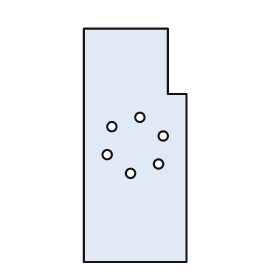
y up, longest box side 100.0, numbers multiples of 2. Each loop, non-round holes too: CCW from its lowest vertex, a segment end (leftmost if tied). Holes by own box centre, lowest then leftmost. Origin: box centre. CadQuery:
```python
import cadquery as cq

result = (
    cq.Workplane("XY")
    .moveTo(-22.0, -50.0)
    .lineTo(22.0, -50.0)
    .lineTo(22.0, 22.0)
    .lineTo(14.0, 22.0)
    .lineTo(14.0, 50.0)
    .lineTo(-22.0, 50.0)
    .close()
    .moveTo(-2.0, -12.0)
    .circle(2.0)
    .moveTo(10.0, -8.0)
    .circle(2.0)
    .moveTo(-12.0, -4.0)
    .circle(2.0)
    .moveTo(12.0, 4.0)
    .circle(2.0)
    .moveTo(-10.0, 8.0)
    .circle(2.0)
    .moveTo(2.0, 12.0)
    .circle(2.0)
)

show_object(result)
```